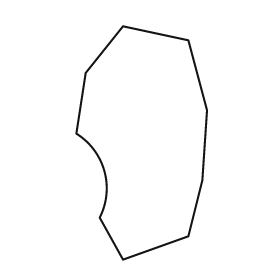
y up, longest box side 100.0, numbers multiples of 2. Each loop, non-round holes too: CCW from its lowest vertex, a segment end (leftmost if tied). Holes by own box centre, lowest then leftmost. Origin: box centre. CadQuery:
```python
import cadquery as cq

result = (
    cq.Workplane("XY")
    .moveTo(-8.0, -50.0)
    .lineTo(20.0, -40.0)
    .lineTo(26.0, -16.0)
    .lineTo(28.0, 14.0)
    .lineTo(20.0, 44.0)
    .lineTo(-8.0, 50.0)
    .lineTo(-24.0, 30.0)
    .lineTo(-28.0, 4.0)
    .threePointArc((-16.0, -12.0), (-18.0, -32.0))
    .close()
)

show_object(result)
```